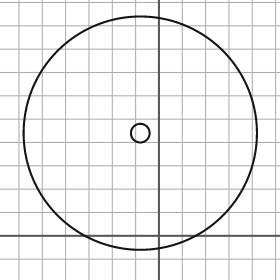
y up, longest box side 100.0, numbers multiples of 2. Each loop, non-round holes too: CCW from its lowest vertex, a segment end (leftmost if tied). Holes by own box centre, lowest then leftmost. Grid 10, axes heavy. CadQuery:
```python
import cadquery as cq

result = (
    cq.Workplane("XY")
    .moveTo(-8.0, 44.0)
    .circle(50.0)
    .moveTo(-8.0, 44.0)
    .circle(4.0)
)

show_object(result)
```